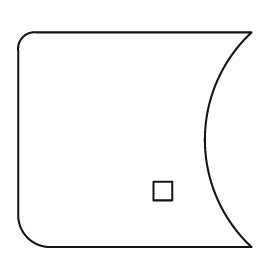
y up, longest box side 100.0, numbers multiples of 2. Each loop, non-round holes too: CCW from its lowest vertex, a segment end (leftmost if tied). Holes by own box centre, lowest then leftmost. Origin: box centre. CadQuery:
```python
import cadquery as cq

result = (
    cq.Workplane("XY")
    .moveTo(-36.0, -46.0)
    .lineTo(50.0, -46.0)
    .threePointArc((30.0, 0.0), (50.0, 46.0))
    .lineTo(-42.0, 46.0)
    .threePointArc((-48.0, 44.0), (-50.0, 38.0))
    .lineTo(-50.0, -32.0)
    .threePointArc((-46.0, -42.0), (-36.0, -46.0))
    .close()
    .moveTo(8.0, -26.0)
    .lineTo(16.0, -26.0)
    .lineTo(16.0, -18.0)
    .lineTo(8.0, -18.0)
    .close()
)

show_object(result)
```